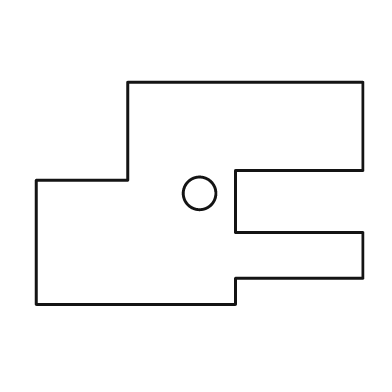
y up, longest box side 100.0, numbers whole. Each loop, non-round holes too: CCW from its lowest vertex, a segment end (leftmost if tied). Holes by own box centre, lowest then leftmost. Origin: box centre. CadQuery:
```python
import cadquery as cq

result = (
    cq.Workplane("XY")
    .moveTo(-50.0, -34.0)
    .lineTo(11.0, -34.0)
    .lineTo(11.0, -26.0)
    .lineTo(50.0, -26.0)
    .lineTo(50.0, -12.0)
    .lineTo(11.0, -12.0)
    .lineTo(11.0, 7.0)
    .lineTo(50.0, 7.0)
    .lineTo(50.0, 34.0)
    .lineTo(-22.0, 34.0)
    .lineTo(-22.0, 4.0)
    .lineTo(-50.0, 4.0)
    .close()
    .moveTo(0.0, 0.0)
    .circle(5.0)
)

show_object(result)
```